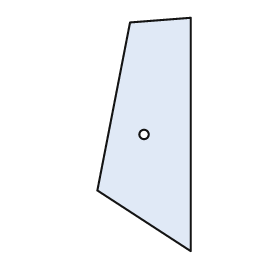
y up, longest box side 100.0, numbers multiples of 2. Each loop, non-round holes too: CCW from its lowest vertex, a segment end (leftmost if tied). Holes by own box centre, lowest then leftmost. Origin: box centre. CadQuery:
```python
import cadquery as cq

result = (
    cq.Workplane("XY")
    .moveTo(20.0, -50.0)
    .lineTo(20.0, 50.0)
    .lineTo(-6.0, 48.0)
    .lineTo(-20.0, -24.0)
    .close()
    .moveTo(0.0, 0.0)
    .circle(2.0)
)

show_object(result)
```